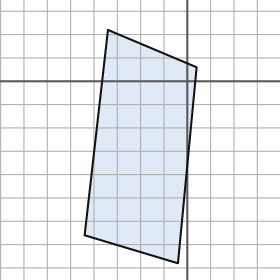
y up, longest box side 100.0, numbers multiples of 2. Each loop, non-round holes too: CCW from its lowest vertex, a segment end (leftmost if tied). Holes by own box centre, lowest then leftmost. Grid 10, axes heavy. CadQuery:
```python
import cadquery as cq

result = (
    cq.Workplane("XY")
    .moveTo(-4.0, -78.0)
    .lineTo(4.0, 6.0)
    .lineTo(-34.0, 22.0)
    .lineTo(-44.0, -66.0)
    .close()
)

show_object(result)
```